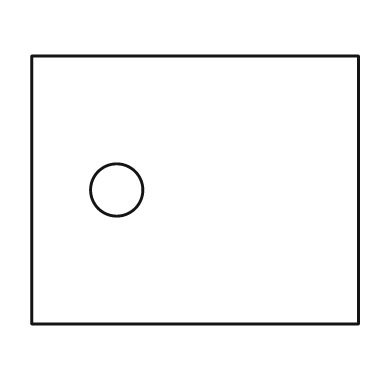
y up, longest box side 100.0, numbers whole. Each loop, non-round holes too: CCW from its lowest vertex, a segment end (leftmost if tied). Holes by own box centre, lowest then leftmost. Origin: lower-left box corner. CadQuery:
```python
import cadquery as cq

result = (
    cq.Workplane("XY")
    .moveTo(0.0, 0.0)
    .lineTo(100.0, 0.0)
    .lineTo(100.0, 82.0)
    .lineTo(0.0, 82.0)
    .close()
    .moveTo(26.0, 41.0)
    .circle(8.0)
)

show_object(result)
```